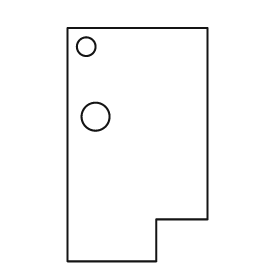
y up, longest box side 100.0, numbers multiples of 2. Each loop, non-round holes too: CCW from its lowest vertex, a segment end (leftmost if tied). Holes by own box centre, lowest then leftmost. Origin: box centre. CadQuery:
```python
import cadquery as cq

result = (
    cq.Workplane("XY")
    .moveTo(-30.0, -50.0)
    .lineTo(8.0, -50.0)
    .lineTo(8.0, -32.0)
    .lineTo(30.0, -32.0)
    .lineTo(30.0, 50.0)
    .lineTo(-30.0, 50.0)
    .close()
    .moveTo(-18.0, 12.0)
    .circle(6.0)
    .moveTo(-22.0, 42.0)
    .circle(4.0)
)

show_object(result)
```